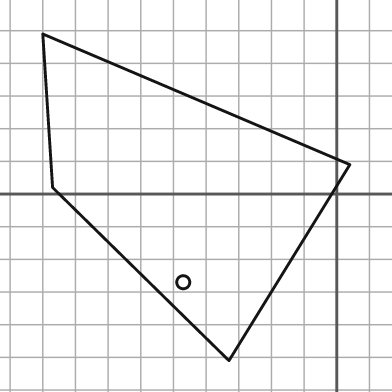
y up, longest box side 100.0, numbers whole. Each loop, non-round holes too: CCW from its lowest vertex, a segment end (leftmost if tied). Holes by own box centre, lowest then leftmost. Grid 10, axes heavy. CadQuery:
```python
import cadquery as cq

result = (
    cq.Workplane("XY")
    .moveTo(-33.0, -51.0)
    .lineTo(4.0, 9.0)
    .lineTo(-90.0, 49.0)
    .lineTo(-87.0, 2.0)
    .close()
    .moveTo(-47.0, -27.0)
    .circle(2.0)
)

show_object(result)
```